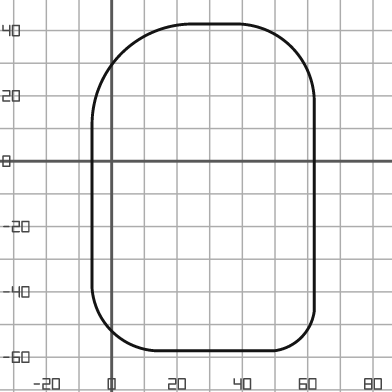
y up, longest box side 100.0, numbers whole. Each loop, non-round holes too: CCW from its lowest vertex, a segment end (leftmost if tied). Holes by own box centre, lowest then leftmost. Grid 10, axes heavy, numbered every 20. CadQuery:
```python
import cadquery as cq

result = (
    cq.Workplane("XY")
    .moveTo(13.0, -58.0)
    .lineTo(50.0, -58.0)
    .threePointArc((58.0, -54.0), (62.0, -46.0))
    .lineTo(62.0, 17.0)
    .threePointArc((55.0, 35.0), (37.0, 42.0))
    .lineTo(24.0, 42.0)
    .threePointArc((3.0, 33.0), (-6.0, 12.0))
    .lineTo(-6.0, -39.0)
    .threePointArc((0.0, -52.0), (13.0, -58.0))
    .close()
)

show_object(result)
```